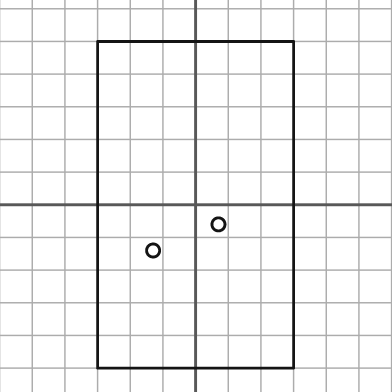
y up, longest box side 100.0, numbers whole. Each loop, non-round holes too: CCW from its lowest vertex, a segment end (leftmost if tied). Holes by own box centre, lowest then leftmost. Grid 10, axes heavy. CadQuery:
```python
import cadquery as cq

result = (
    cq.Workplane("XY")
    .moveTo(-30.0, -50.0)
    .lineTo(30.0, -50.0)
    .lineTo(30.0, 50.0)
    .lineTo(-30.0, 50.0)
    .close()
    .moveTo(-13.0, -14.0)
    .circle(2.0)
    .moveTo(7.0, -6.0)
    .circle(2.0)
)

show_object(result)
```